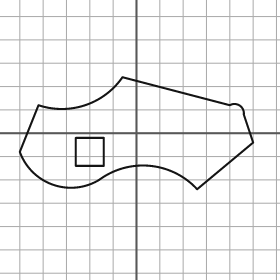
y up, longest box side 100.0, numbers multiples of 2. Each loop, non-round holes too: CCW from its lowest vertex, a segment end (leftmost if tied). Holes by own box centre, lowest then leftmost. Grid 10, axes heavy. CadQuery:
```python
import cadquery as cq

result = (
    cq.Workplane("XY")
    .moveTo(26.0, -24.0)
    .lineTo(50.0, -4.0)
    .lineTo(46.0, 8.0)
    .threePointArc((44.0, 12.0), (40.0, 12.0))
    .lineTo(-6.0, 24.0)
    .threePointArc((-22.0, 12.0), (-42.0, 12.0))
    .lineTo(-50.0, -8.0)
    .threePointArc((-36.0, -22.0), (-16.0, -20.0))
    .threePointArc((6.0, -14.0), (26.0, -24.0))
    .close()
    .moveTo(-26.0, -14.0)
    .lineTo(-14.0, -14.0)
    .lineTo(-14.0, -2.0)
    .lineTo(-26.0, -2.0)
    .close()
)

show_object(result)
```